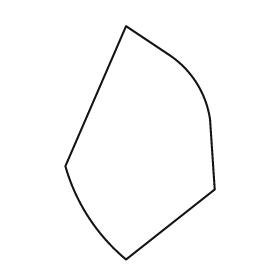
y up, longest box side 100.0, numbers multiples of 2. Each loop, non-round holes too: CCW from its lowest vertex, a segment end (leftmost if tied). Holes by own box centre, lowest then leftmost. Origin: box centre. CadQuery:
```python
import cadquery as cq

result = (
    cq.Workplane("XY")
    .moveTo(-6.0, -50.0)
    .lineTo(32.0, -20.0)
    .lineTo(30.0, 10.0)
    .threePointArc((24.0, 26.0), (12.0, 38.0))
    .lineTo(-6.0, 50.0)
    .lineTo(-32.0, -10.0)
    .threePointArc((-22.0, -32.0), (-6.0, -50.0))
    .close()
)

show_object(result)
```